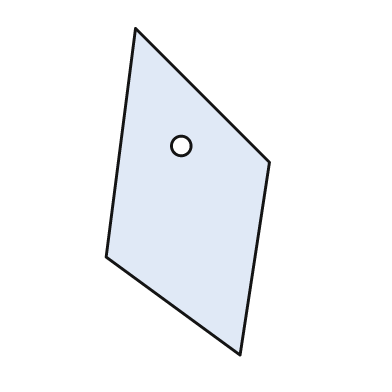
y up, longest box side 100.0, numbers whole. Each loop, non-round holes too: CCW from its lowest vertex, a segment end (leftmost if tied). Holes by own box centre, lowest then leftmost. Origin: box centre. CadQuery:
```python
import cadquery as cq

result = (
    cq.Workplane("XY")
    .moveTo(16.0, -50.0)
    .lineTo(25.0, 9.0)
    .lineTo(-16.0, 50.0)
    .lineTo(-25.0, -20.0)
    .close()
    .moveTo(-2.0, 14.0)
    .circle(3.0)
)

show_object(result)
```